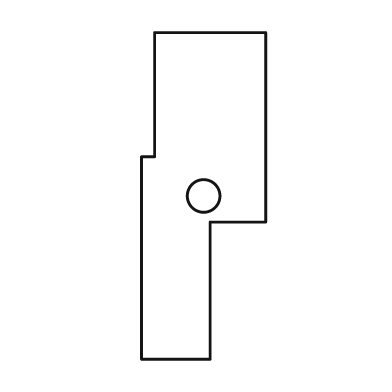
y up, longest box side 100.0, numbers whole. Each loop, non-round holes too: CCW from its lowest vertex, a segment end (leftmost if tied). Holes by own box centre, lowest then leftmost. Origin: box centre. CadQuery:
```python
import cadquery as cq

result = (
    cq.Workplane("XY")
    .moveTo(-19.0, -50.0)
    .lineTo(2.0, -50.0)
    .lineTo(2.0, -8.0)
    .lineTo(19.0, -8.0)
    .lineTo(19.0, 50.0)
    .lineTo(-15.0, 50.0)
    .lineTo(-15.0, 12.0)
    .lineTo(-19.0, 12.0)
    .close()
    .moveTo(0.0, 0.0)
    .circle(5.0)
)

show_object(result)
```